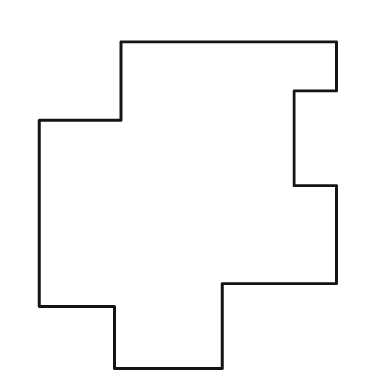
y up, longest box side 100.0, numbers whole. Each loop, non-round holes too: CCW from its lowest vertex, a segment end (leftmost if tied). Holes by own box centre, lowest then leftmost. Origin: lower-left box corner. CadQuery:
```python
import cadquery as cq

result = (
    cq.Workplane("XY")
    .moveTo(23.0, 0.0)
    .lineTo(56.0, 0.0)
    .lineTo(56.0, 26.0)
    .lineTo(91.0, 26.0)
    .lineTo(91.0, 56.0)
    .lineTo(78.0, 56.0)
    .lineTo(78.0, 85.0)
    .lineTo(91.0, 85.0)
    .lineTo(91.0, 100.0)
    .lineTo(25.0, 100.0)
    .lineTo(25.0, 76.0)
    .lineTo(0.0, 76.0)
    .lineTo(0.0, 19.0)
    .lineTo(23.0, 19.0)
    .close()
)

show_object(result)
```